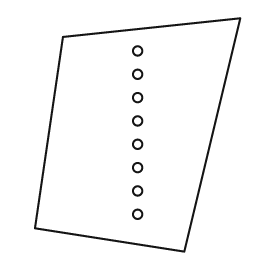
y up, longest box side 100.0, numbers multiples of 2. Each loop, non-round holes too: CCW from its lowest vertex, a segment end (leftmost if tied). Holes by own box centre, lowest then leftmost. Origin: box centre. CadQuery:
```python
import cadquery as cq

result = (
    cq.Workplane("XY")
    .moveTo(20.0, -50.0)
    .lineTo(44.0, 50.0)
    .lineTo(-32.0, 42.0)
    .lineTo(-44.0, -40.0)
    .close()
    .moveTo(0.0, -34.0)
    .circle(2.0)
    .moveTo(0.0, -24.0)
    .circle(2.0)
    .moveTo(0.0, -14.0)
    .circle(2.0)
    .moveTo(0.0, -4.0)
    .circle(2.0)
    .moveTo(0.0, 6.0)
    .circle(2.0)
    .moveTo(0.0, 16.0)
    .circle(2.0)
    .moveTo(0.0, 26.0)
    .circle(2.0)
    .moveTo(0.0, 36.0)
    .circle(2.0)
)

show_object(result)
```